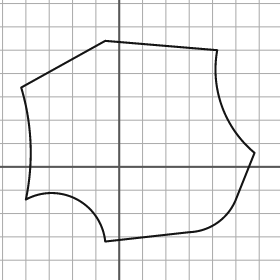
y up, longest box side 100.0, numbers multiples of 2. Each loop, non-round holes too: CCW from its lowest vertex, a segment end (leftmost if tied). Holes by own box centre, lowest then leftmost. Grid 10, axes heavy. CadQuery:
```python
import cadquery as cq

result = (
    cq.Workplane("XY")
    .moveTo(-6.0, -32.0)
    .lineTo(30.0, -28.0)
    .threePointArc((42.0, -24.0), (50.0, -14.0))
    .lineTo(58.0, 6.0)
    .threePointArc((44.0, 26.0), (42.0, 50.0))
    .lineTo(-6.0, 54.0)
    .lineTo(-42.0, 34.0)
    .threePointArc((-38.0, 10.0), (-40.0, -14.0))
    .threePointArc((-18.0, -14.0), (-6.0, -32.0))
    .close()
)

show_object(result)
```